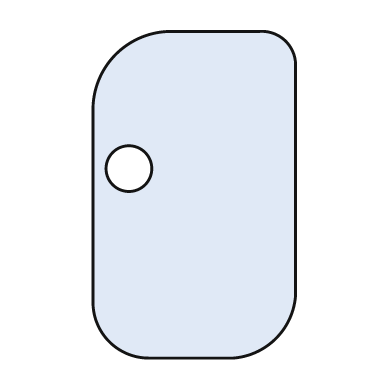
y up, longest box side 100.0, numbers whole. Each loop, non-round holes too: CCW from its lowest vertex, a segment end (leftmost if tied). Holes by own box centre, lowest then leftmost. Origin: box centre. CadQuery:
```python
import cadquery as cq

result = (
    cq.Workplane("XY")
    .moveTo(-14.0, -50.0)
    .lineTo(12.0, -50.0)
    .threePointArc((25.0, -44.0), (31.0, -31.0))
    .lineTo(31.0, 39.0)
    .threePointArc((28.0, 47.0), (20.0, 50.0))
    .lineTo(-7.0, 50.0)
    .threePointArc((-24.0, 43.0), (-31.0, 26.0))
    .lineTo(-31.0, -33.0)
    .threePointArc((-26.0, -45.0), (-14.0, -50.0))
    .close()
    .moveTo(-20.0, 8.0)
    .circle(7.0)
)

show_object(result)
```